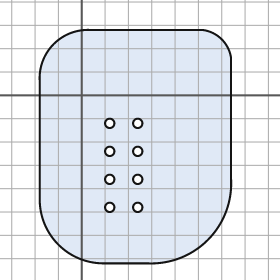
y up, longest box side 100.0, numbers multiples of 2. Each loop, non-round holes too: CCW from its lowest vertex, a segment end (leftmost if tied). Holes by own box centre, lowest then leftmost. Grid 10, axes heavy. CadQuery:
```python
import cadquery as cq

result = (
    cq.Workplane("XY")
    .moveTo(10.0, -72.0)
    .lineTo(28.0, -72.0)
    .threePointArc((54.0, -62.0), (64.0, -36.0))
    .lineTo(64.0, 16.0)
    .threePointArc((60.0, 24.0), (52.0, 28.0))
    .lineTo(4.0, 28.0)
    .threePointArc((-12.0, 22.0), (-18.0, 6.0))
    .lineTo(-18.0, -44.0)
    .threePointArc((-10.0, -64.0), (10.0, -72.0))
    .close()
    .moveTo(12.0, -48.0)
    .circle(2.0)
    .moveTo(24.0, -48.0)
    .circle(2.0)
    .moveTo(12.0, -36.0)
    .circle(2.0)
    .moveTo(24.0, -36.0)
    .circle(2.0)
    .moveTo(12.0, -24.0)
    .circle(2.0)
    .moveTo(24.0, -24.0)
    .circle(2.0)
    .moveTo(12.0, -12.0)
    .circle(2.0)
    .moveTo(24.0, -12.0)
    .circle(2.0)
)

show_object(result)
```